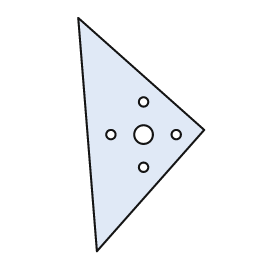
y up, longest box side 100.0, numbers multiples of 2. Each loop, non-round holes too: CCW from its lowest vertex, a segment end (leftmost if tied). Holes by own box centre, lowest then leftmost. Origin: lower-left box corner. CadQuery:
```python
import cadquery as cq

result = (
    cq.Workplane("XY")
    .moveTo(8.0, 0.0)
    .lineTo(54.0, 52.0)
    .lineTo(0.0, 100.0)
    .close()
    .moveTo(28.0, 36.0)
    .circle(2.0)
    .moveTo(14.0, 50.0)
    .circle(2.0)
    .moveTo(28.0, 50.0)
    .circle(4.0)
    .moveTo(42.0, 50.0)
    .circle(2.0)
    .moveTo(28.0, 64.0)
    .circle(2.0)
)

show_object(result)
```